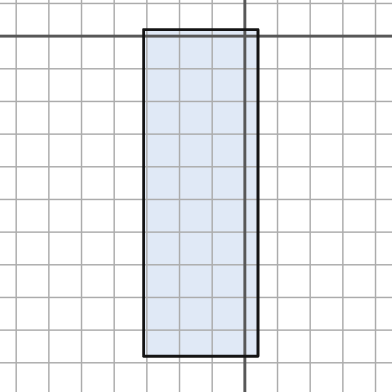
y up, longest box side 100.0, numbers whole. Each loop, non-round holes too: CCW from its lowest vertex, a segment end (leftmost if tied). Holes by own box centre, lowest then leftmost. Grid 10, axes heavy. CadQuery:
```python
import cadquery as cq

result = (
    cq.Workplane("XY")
    .moveTo(-31.0, -98.0)
    .lineTo(4.0, -98.0)
    .lineTo(4.0, 2.0)
    .lineTo(-31.0, 2.0)
    .close()
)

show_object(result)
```